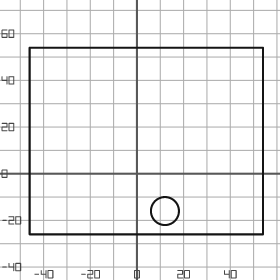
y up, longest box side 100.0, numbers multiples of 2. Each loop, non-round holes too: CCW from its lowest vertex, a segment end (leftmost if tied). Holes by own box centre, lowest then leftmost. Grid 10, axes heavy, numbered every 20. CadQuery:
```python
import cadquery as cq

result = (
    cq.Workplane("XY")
    .moveTo(-46.0, -26.0)
    .lineTo(54.0, -26.0)
    .lineTo(54.0, 54.0)
    .lineTo(-46.0, 54.0)
    .close()
    .moveTo(12.0, -16.0)
    .circle(6.0)
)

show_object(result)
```